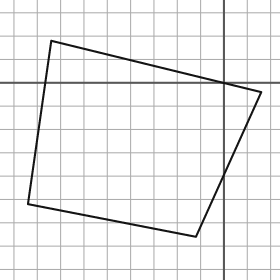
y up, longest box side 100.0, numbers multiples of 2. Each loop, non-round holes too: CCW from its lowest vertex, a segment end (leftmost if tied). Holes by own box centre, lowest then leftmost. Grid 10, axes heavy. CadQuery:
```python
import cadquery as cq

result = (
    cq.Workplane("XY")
    .moveTo(-12.0, -66.0)
    .lineTo(16.0, -4.0)
    .lineTo(-74.0, 18.0)
    .lineTo(-84.0, -52.0)
    .close()
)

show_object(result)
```